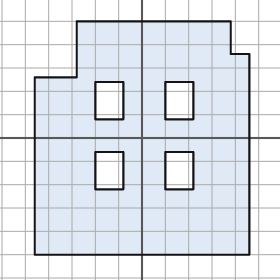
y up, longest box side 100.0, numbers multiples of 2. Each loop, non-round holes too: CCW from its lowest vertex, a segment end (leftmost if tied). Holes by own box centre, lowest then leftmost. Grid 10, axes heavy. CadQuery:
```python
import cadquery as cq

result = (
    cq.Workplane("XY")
    .moveTo(-46.0, -50.0)
    .lineTo(46.0, -50.0)
    .lineTo(46.0, 36.0)
    .lineTo(38.0, 36.0)
    .lineTo(38.0, 50.0)
    .lineTo(-28.0, 50.0)
    .lineTo(-28.0, 26.0)
    .lineTo(-46.0, 26.0)
    .close()
    .moveTo(-20.0, -22.0)
    .lineTo(-8.0, -22.0)
    .lineTo(-8.0, -6.0)
    .lineTo(-20.0, -6.0)
    .close()
    .moveTo(10.0, -22.0)
    .lineTo(22.0, -22.0)
    .lineTo(22.0, -6.0)
    .lineTo(10.0, -6.0)
    .close()
    .moveTo(-20.0, 8.0)
    .lineTo(-8.0, 8.0)
    .lineTo(-8.0, 24.0)
    .lineTo(-20.0, 24.0)
    .close()
    .moveTo(10.0, 8.0)
    .lineTo(22.0, 8.0)
    .lineTo(22.0, 24.0)
    .lineTo(10.0, 24.0)
    .close()
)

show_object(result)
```